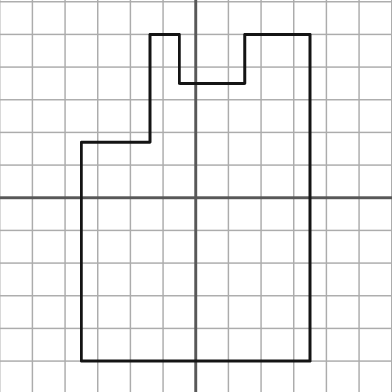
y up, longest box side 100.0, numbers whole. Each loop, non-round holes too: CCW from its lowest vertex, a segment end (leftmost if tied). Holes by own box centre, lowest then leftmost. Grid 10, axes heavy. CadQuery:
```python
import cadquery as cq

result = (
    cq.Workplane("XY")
    .moveTo(-35.0, -50.0)
    .lineTo(35.0, -50.0)
    .lineTo(35.0, 50.0)
    .lineTo(15.0, 50.0)
    .lineTo(15.0, 35.0)
    .lineTo(-5.0, 35.0)
    .lineTo(-5.0, 50.0)
    .lineTo(-14.0, 50.0)
    .lineTo(-14.0, 17.0)
    .lineTo(-35.0, 17.0)
    .close()
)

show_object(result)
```